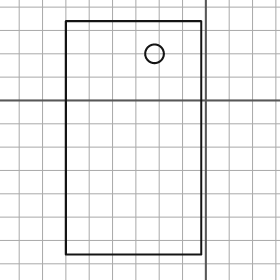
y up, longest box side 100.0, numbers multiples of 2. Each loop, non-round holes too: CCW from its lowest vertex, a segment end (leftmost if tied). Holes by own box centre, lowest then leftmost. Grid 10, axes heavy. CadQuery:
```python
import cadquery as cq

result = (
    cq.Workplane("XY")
    .moveTo(-60.0, -66.0)
    .lineTo(-2.0, -66.0)
    .lineTo(-2.0, 34.0)
    .lineTo(-60.0, 34.0)
    .close()
    .moveTo(-22.0, 20.0)
    .circle(4.0)
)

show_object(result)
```